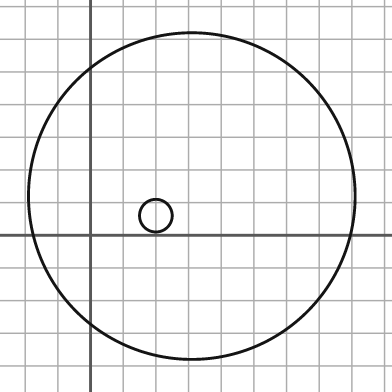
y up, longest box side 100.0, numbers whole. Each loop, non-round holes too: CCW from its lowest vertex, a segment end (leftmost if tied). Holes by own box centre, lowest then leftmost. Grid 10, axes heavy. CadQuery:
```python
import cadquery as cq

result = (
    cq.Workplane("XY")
    .moveTo(31.0, 12.0)
    .circle(50.0)
    .moveTo(20.0, 6.0)
    .circle(5.0)
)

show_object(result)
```